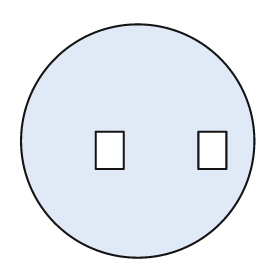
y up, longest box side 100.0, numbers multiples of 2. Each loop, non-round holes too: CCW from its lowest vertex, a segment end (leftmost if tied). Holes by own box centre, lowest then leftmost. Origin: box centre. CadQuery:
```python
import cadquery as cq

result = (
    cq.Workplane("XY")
    .moveTo(0.0, 0.0)
    .circle(50.0)
    .moveTo(-18.0, -12.0)
    .lineTo(-6.0, -12.0)
    .lineTo(-6.0, 4.0)
    .lineTo(-18.0, 4.0)
    .close()
    .moveTo(26.0, -12.0)
    .lineTo(38.0, -12.0)
    .lineTo(38.0, 4.0)
    .lineTo(26.0, 4.0)
    .close()
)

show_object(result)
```